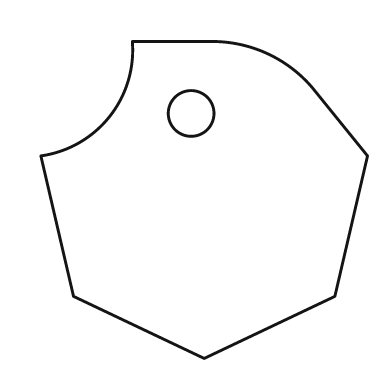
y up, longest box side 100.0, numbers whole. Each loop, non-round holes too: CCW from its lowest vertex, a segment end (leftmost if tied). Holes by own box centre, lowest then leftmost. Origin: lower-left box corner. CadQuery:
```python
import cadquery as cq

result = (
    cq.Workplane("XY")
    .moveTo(50.0, 0.0)
    .lineTo(90.0, 19.0)
    .lineTo(100.0, 62.0)
    .lineTo(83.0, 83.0)
    .threePointArc((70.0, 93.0), (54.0, 97.0))
    .lineTo(28.0, 97.0)
    .threePointArc((21.0, 74.0), (0.0, 62.0))
    .lineTo(10.0, 19.0)
    .close()
    .moveTo(46.0, 75.0)
    .circle(7.0)
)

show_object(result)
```